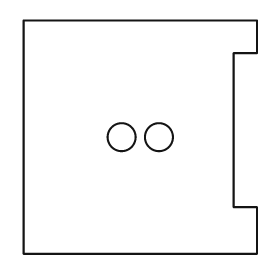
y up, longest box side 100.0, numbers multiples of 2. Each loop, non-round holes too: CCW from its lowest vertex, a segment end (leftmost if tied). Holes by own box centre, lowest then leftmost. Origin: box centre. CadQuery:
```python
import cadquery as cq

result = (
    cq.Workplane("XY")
    .moveTo(-50.0, -50.0)
    .lineTo(50.0, -50.0)
    .lineTo(50.0, -30.0)
    .lineTo(40.0, -30.0)
    .lineTo(40.0, 36.0)
    .lineTo(50.0, 36.0)
    .lineTo(50.0, 50.0)
    .lineTo(-50.0, 50.0)
    .close()
    .moveTo(-8.0, 0.0)
    .circle(6.0)
    .moveTo(8.0, 0.0)
    .circle(6.0)
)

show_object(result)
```